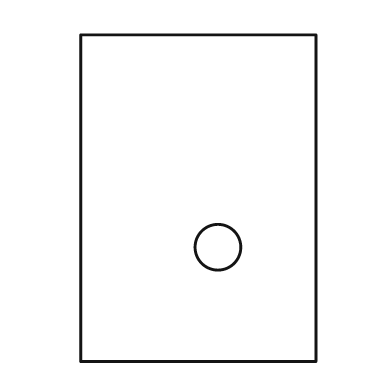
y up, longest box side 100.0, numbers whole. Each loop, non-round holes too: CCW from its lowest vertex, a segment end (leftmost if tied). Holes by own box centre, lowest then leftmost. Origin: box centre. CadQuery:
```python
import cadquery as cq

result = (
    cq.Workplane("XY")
    .moveTo(-36.0, -50.0)
    .lineTo(36.0, -50.0)
    .lineTo(36.0, 50.0)
    .lineTo(-36.0, 50.0)
    .close()
    .moveTo(6.0, -15.0)
    .circle(7.0)
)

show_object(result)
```